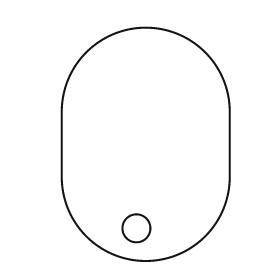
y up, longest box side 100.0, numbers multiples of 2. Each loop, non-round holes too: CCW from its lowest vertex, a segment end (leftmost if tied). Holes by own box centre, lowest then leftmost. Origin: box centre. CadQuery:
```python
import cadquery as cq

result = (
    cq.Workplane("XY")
    .moveTo(-36.0, -14.0)
    .threePointArc((0.0, -50.0), (36.0, -14.0))
    .lineTo(36.0, 14.0)
    .threePointArc((0.0, 50.0), (-36.0, 14.0))
    .close()
    .moveTo(-4.0, -36.0)
    .circle(6.0)
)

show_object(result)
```